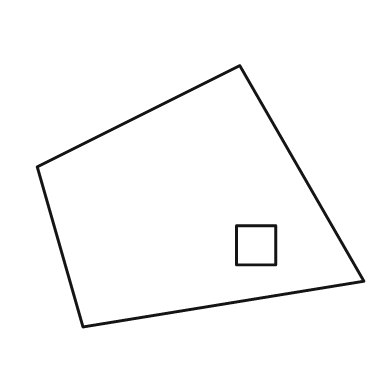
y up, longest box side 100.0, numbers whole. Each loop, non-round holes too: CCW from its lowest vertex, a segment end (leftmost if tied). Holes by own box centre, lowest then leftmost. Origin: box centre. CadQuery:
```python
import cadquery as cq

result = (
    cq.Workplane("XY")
    .moveTo(-36.0, -40.0)
    .lineTo(50.0, -26.0)
    .lineTo(12.0, 40.0)
    .lineTo(-50.0, 9.0)
    .close()
    .moveTo(11.0, -21.0)
    .lineTo(23.0, -21.0)
    .lineTo(23.0, -9.0)
    .lineTo(11.0, -9.0)
    .close()
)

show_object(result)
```